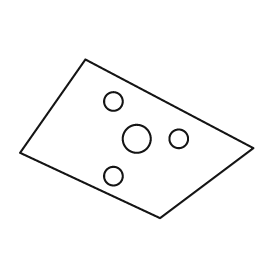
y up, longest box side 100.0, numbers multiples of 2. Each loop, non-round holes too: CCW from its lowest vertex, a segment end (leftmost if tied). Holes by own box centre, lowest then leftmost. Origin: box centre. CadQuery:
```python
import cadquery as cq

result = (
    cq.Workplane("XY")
    .moveTo(10.0, -34.0)
    .lineTo(50.0, -4.0)
    .lineTo(-22.0, 34.0)
    .lineTo(-50.0, -6.0)
    .close()
    .moveTo(-10.0, -16.0)
    .circle(4.0)
    .moveTo(0.0, 0.0)
    .circle(6.0)
    .moveTo(18.0, 0.0)
    .circle(4.0)
    .moveTo(-10.0, 16.0)
    .circle(4.0)
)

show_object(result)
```